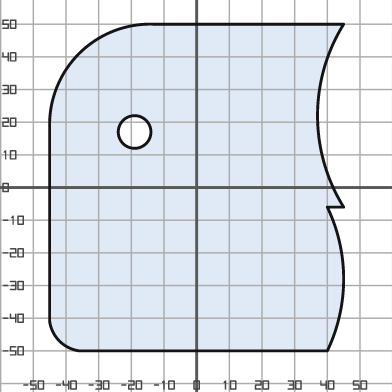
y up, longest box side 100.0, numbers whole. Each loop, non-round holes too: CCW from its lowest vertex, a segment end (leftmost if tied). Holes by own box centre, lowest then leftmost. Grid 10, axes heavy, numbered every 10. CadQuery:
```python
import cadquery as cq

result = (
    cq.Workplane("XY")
    .moveTo(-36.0, -50.0)
    .lineTo(40.0, -50.0)
    .threePointArc((45.0, -28.0), (40.0, -6.0))
    .lineTo(45.0, -6.0)
    .threePointArc((37.0, 22.0), (45.0, 50.0))
    .lineTo(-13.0, 50.0)
    .threePointArc((-36.0, 41.0), (-45.0, 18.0))
    .lineTo(-45.0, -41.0)
    .threePointArc((-42.0, -47.0), (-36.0, -50.0))
    .close()
    .moveTo(-19.0, 17.0)
    .circle(5.0)
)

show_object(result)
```